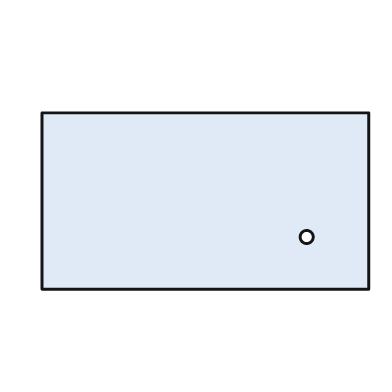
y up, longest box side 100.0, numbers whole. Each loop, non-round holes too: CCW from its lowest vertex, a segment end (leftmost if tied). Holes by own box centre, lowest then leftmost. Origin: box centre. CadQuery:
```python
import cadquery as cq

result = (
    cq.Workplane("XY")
    .moveTo(-50.0, -27.0)
    .lineTo(50.0, -27.0)
    .lineTo(50.0, 27.0)
    .lineTo(-50.0, 27.0)
    .close()
    .moveTo(31.0, -11.0)
    .circle(2.0)
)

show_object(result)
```